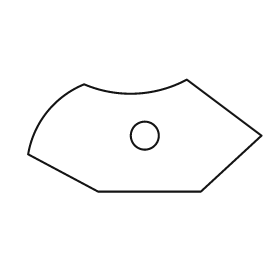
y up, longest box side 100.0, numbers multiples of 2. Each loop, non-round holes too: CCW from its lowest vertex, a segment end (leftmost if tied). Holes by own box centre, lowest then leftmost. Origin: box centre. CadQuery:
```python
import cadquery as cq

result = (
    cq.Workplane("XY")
    .moveTo(-20.0, -24.0)
    .lineTo(24.0, -24.0)
    .lineTo(50.0, 0.0)
    .lineTo(18.0, 24.0)
    .threePointArc((-4.0, 18.0), (-26.0, 22.0))
    .threePointArc((-42.0, 10.0), (-50.0, -8.0))
    .close()
    .moveTo(0.0, 0.0)
    .circle(6.0)
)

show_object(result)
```